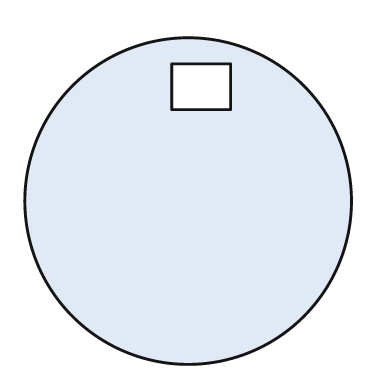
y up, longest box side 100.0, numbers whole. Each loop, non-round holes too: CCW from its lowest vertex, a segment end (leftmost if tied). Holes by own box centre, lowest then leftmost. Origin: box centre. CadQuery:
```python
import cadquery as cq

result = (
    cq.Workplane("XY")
    .moveTo(0.0, 0.0)
    .circle(50.0)
    .moveTo(-5.0, 28.0)
    .lineTo(13.0, 28.0)
    .lineTo(13.0, 42.0)
    .lineTo(-5.0, 42.0)
    .close()
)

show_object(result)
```